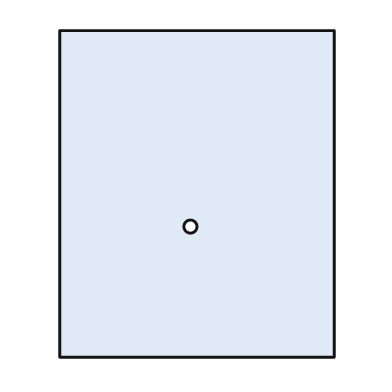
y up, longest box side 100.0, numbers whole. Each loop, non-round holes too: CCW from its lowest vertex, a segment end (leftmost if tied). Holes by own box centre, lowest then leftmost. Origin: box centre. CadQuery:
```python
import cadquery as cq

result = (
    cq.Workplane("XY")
    .moveTo(-42.0, -50.0)
    .lineTo(42.0, -50.0)
    .lineTo(42.0, 50.0)
    .lineTo(-42.0, 50.0)
    .close()
    .moveTo(-2.0, -10.0)
    .circle(2.0)
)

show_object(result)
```